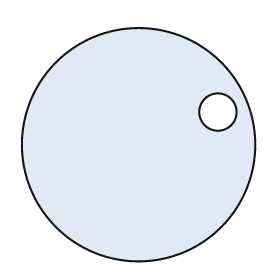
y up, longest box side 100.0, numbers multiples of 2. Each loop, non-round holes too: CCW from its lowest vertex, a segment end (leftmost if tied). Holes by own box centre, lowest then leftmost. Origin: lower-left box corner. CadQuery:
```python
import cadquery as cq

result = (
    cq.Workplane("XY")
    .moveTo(50.0, 50.0)
    .circle(50.0)
    .moveTo(84.0, 64.0)
    .circle(8.0)
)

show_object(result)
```